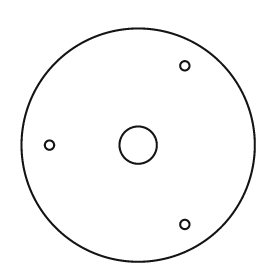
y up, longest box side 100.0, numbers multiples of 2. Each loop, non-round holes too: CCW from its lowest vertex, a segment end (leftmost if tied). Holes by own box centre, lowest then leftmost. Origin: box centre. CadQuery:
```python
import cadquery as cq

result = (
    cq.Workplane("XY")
    .moveTo(0.0, 0.0)
    .circle(50.0)
    .moveTo(20.0, -34.0)
    .circle(2.0)
    .moveTo(-38.0, 0.0)
    .circle(2.0)
    .moveTo(0.0, 0.0)
    .circle(8.0)
    .moveTo(20.0, 34.0)
    .circle(2.0)
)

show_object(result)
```